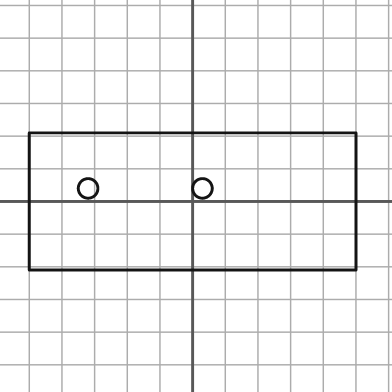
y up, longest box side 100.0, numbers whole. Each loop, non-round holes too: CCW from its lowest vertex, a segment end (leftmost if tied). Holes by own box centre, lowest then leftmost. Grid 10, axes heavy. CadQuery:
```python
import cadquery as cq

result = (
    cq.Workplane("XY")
    .moveTo(-50.0, -21.0)
    .lineTo(50.0, -21.0)
    .lineTo(50.0, 21.0)
    .lineTo(-50.0, 21.0)
    .close()
    .moveTo(-32.0, 4.0)
    .circle(3.0)
    .moveTo(3.0, 4.0)
    .circle(3.0)
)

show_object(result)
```